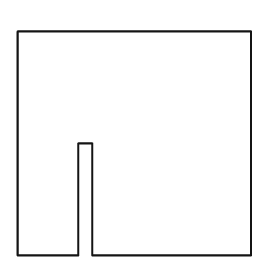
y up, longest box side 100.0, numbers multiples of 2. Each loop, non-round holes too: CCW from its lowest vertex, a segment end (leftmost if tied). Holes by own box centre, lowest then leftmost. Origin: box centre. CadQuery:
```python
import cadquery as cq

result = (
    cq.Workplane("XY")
    .moveTo(-50.0, -48.0)
    .lineTo(-24.0, -48.0)
    .lineTo(-24.0, 0.0)
    .lineTo(-18.0, 0.0)
    .lineTo(-18.0, -48.0)
    .lineTo(50.0, -48.0)
    .lineTo(50.0, 48.0)
    .lineTo(-50.0, 48.0)
    .close()
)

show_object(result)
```